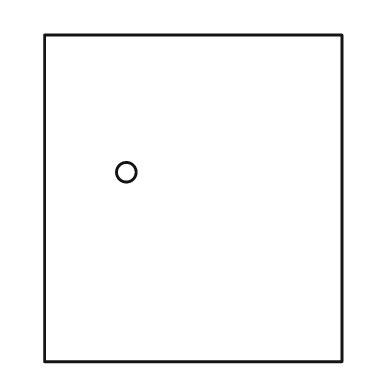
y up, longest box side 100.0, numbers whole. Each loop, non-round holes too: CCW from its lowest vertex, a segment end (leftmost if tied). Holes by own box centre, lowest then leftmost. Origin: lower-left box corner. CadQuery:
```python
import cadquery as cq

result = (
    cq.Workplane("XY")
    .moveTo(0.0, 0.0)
    .lineTo(91.0, 0.0)
    .lineTo(91.0, 100.0)
    .lineTo(0.0, 100.0)
    .close()
    .moveTo(25.0, 58.0)
    .circle(3.0)
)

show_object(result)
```